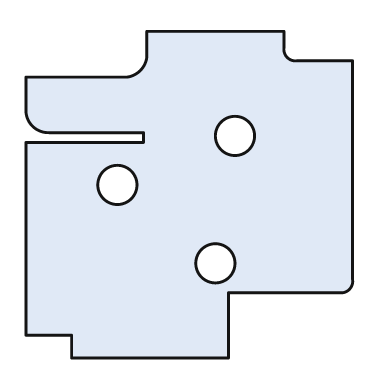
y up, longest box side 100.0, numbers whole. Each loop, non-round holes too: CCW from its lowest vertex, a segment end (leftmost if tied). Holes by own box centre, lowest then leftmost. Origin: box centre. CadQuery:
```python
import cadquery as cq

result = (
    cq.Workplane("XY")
    .moveTo(-36.0, -50.0)
    .lineTo(12.0, -50.0)
    .lineTo(12.0, -30.0)
    .lineTo(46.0, -30.0)
    .threePointArc((49.0, -29.0), (50.0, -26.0))
    .lineTo(50.0, 41.0)
    .lineTo(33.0, 41.0)
    .threePointArc((30.0, 42.0), (29.0, 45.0))
    .lineTo(29.0, 50.0)
    .lineTo(-13.0, 50.0)
    .lineTo(-13.0, 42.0)
    .threePointArc((-15.0, 38.0), (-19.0, 36.0))
    .lineTo(-50.0, 36.0)
    .lineTo(-50.0, 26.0)
    .threePointArc((-48.0, 21.0), (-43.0, 19.0))
    .lineTo(-14.0, 19.0)
    .lineTo(-14.0, 16.0)
    .lineTo(-50.0, 16.0)
    .lineTo(-50.0, -43.0)
    .lineTo(-36.0, -43.0)
    .close()
    .moveTo(8.0, -21.0)
    .circle(6.0)
    .moveTo(-22.0, 3.0)
    .circle(6.0)
    .moveTo(14.0, 18.0)
    .circle(6.0)
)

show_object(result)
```